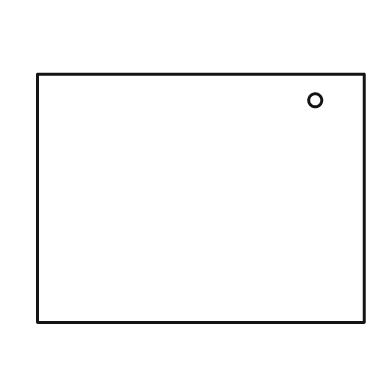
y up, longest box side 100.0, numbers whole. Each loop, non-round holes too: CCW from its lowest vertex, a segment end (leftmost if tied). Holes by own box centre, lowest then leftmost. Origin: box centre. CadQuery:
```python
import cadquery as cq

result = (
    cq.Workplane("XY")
    .moveTo(-50.0, -38.0)
    .lineTo(50.0, -38.0)
    .lineTo(50.0, 38.0)
    .lineTo(-50.0, 38.0)
    .close()
    .moveTo(35.0, 30.0)
    .circle(2.0)
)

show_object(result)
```